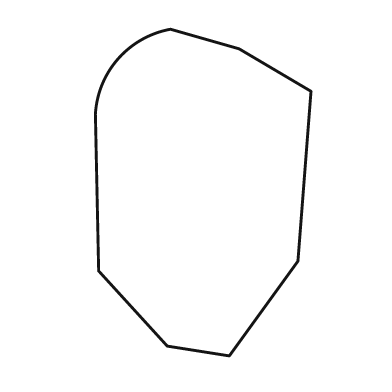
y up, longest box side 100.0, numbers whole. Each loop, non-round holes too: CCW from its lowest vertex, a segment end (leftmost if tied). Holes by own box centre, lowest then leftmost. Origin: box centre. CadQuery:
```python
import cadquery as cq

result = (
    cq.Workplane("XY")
    .moveTo(8.0, -50.0)
    .lineTo(29.0, -21.0)
    .lineTo(33.0, 31.0)
    .lineTo(11.0, 44.0)
    .lineTo(-10.0, 50.0)
    .threePointArc((-26.0, 41.0), (-33.0, 24.0))
    .lineTo(-32.0, -24.0)
    .lineTo(-11.0, -47.0)
    .close()
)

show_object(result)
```